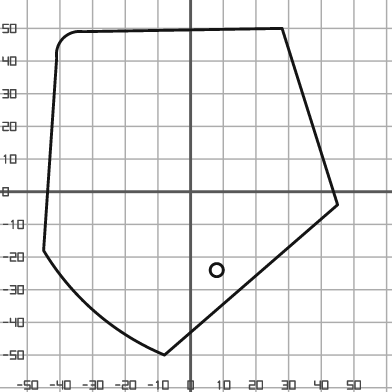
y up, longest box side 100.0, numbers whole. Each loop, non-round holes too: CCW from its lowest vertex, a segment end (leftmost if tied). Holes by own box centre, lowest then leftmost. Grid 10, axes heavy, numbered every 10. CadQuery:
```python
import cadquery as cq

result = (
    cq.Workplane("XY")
    .moveTo(-8.0, -50.0)
    .lineTo(45.0, -4.0)
    .lineTo(28.0, 50.0)
    .lineTo(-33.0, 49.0)
    .threePointArc((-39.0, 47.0), (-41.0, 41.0))
    .lineTo(-45.0, -18.0)
    .threePointArc((-29.0, -37.0), (-8.0, -50.0))
    .close()
    .moveTo(8.0, -24.0)
    .circle(2.0)
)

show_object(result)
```